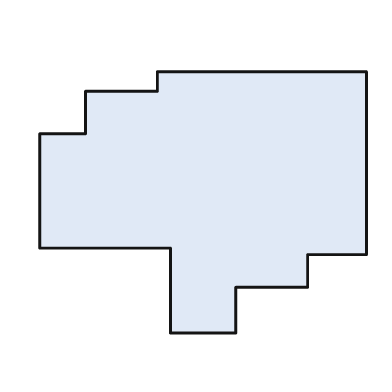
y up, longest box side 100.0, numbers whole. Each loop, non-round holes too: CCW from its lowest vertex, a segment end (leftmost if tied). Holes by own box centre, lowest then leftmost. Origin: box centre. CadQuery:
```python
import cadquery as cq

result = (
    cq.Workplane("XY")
    .moveTo(-10.0, -40.0)
    .lineTo(10.0, -40.0)
    .lineTo(10.0, -26.0)
    .lineTo(32.0, -26.0)
    .lineTo(32.0, -16.0)
    .lineTo(50.0, -16.0)
    .lineTo(50.0, 40.0)
    .lineTo(-14.0, 40.0)
    .lineTo(-14.0, 34.0)
    .lineTo(-36.0, 34.0)
    .lineTo(-36.0, 21.0)
    .lineTo(-50.0, 21.0)
    .lineTo(-50.0, -14.0)
    .lineTo(-10.0, -14.0)
    .close()
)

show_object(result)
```